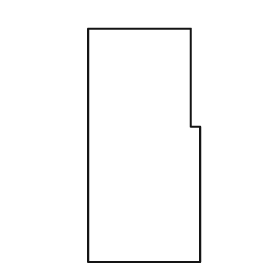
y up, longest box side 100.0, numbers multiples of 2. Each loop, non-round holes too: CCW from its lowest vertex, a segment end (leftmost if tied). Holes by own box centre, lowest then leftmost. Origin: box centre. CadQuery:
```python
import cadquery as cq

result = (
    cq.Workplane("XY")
    .moveTo(-24.0, -50.0)
    .lineTo(24.0, -50.0)
    .lineTo(24.0, 8.0)
    .lineTo(20.0, 8.0)
    .lineTo(20.0, 50.0)
    .lineTo(-24.0, 50.0)
    .close()
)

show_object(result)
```